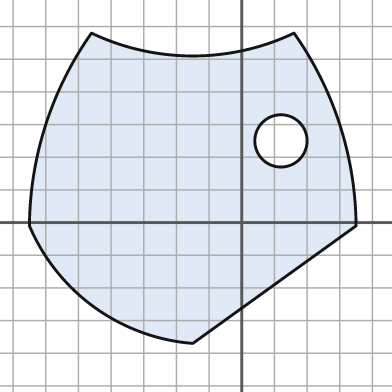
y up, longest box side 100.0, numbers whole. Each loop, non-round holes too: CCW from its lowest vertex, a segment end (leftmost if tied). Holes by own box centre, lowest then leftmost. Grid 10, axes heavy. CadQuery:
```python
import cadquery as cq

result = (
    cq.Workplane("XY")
    .moveTo(-15.0, -37.0)
    .lineTo(35.0, -1.0)
    .threePointArc((30.0, 30.0), (16.0, 58.0))
    .threePointArc((-15.0, 51.0), (-46.0, 58.0))
    .threePointArc((-60.0, 30.0), (-65.0, -1.0))
    .threePointArc((-45.0, -26.0), (-15.0, -37.0))
    .close()
    .moveTo(12.0, 25.0)
    .circle(8.0)
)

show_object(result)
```